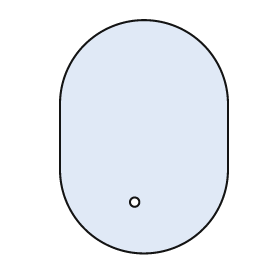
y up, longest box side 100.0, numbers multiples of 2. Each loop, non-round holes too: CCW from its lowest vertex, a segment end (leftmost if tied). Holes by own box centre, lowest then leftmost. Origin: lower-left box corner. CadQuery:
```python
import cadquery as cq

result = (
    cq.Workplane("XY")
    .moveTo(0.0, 36.0)
    .threePointArc((36.0, 0.0), (72.0, 36.0))
    .lineTo(72.0, 64.0)
    .threePointArc((36.0, 100.0), (0.0, 64.0))
    .close()
    .moveTo(32.0, 22.0)
    .circle(2.0)
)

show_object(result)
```